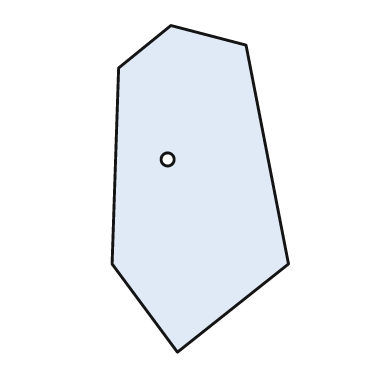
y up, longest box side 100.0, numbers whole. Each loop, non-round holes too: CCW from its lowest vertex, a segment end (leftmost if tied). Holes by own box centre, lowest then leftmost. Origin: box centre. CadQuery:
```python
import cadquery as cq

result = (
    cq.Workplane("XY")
    .moveTo(-7.0, -50.0)
    .lineTo(27.0, -23.0)
    .lineTo(14.0, 44.0)
    .lineTo(-9.0, 50.0)
    .lineTo(-25.0, 37.0)
    .lineTo(-27.0, -23.0)
    .close()
    .moveTo(-10.0, 9.0)
    .circle(2.0)
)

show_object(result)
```